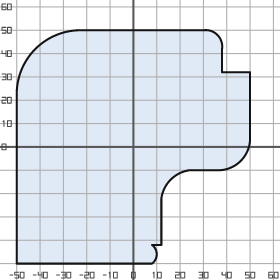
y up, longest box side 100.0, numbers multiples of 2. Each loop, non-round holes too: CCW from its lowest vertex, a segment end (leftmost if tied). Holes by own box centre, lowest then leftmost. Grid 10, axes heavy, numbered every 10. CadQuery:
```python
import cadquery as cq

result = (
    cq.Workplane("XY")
    .moveTo(-50.0, -50.0)
    .lineTo(8.0, -50.0)
    .threePointArc((10.0, -46.0), (8.0, -42.0))
    .lineTo(12.0, -42.0)
    .lineTo(12.0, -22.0)
    .threePointArc((16.0, -14.0), (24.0, -10.0))
    .lineTo(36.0, -10.0)
    .threePointArc((46.0, -6.0), (50.0, 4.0))
    .lineTo(50.0, 32.0)
    .lineTo(38.0, 32.0)
    .lineTo(38.0, 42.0)
    .threePointArc((36.0, 48.0), (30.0, 50.0))
    .lineTo(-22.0, 50.0)
    .threePointArc((-42.0, 42.0), (-50.0, 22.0))
    .close()
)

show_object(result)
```